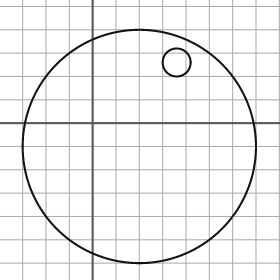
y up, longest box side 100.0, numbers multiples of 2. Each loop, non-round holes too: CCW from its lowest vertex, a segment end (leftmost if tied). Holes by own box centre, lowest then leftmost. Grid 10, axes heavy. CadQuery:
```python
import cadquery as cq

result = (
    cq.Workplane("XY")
    .moveTo(20.0, -10.0)
    .circle(50.0)
    .moveTo(36.0, 26.0)
    .circle(6.0)
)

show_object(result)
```